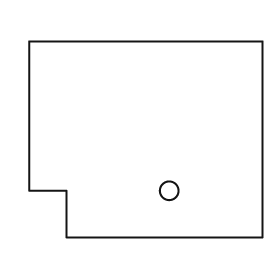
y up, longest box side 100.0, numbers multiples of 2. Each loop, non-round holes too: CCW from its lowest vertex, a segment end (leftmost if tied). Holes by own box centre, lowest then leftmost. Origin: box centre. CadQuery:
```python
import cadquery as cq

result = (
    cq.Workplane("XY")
    .moveTo(-34.0, -42.0)
    .lineTo(50.0, -42.0)
    .lineTo(50.0, 42.0)
    .lineTo(-50.0, 42.0)
    .lineTo(-50.0, -22.0)
    .lineTo(-34.0, -22.0)
    .close()
    .moveTo(10.0, -22.0)
    .circle(4.0)
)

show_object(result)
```